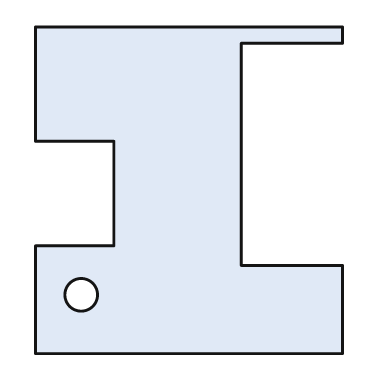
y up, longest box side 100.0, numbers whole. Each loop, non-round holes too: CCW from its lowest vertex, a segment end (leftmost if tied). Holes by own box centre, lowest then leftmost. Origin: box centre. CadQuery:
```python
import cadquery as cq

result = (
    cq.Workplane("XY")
    .moveTo(-47.0, -50.0)
    .lineTo(47.0, -50.0)
    .lineTo(47.0, -23.0)
    .lineTo(16.0, -23.0)
    .lineTo(16.0, 45.0)
    .lineTo(47.0, 45.0)
    .lineTo(47.0, 50.0)
    .lineTo(-47.0, 50.0)
    .lineTo(-47.0, 15.0)
    .lineTo(-23.0, 15.0)
    .lineTo(-23.0, -17.0)
    .lineTo(-47.0, -17.0)
    .close()
    .moveTo(-33.0, -32.0)
    .circle(5.0)
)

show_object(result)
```